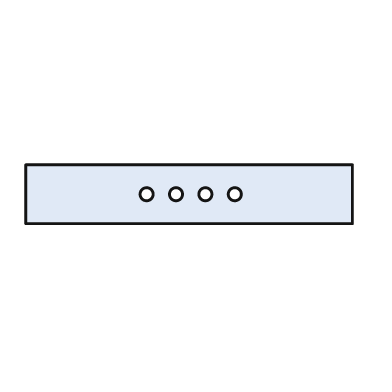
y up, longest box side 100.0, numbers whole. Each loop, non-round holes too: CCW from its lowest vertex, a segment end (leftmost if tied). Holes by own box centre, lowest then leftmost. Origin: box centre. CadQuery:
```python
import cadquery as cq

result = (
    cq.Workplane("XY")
    .moveTo(-50.0, -9.0)
    .lineTo(50.0, -9.0)
    .lineTo(50.0, 9.0)
    .lineTo(-50.0, 9.0)
    .close()
    .moveTo(-13.0, 0.0)
    .circle(2.0)
    .moveTo(-4.0, 0.0)
    .circle(2.0)
    .moveTo(5.0, 0.0)
    .circle(2.0)
    .moveTo(14.0, 0.0)
    .circle(2.0)
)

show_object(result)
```